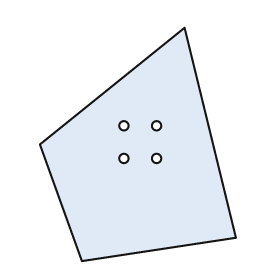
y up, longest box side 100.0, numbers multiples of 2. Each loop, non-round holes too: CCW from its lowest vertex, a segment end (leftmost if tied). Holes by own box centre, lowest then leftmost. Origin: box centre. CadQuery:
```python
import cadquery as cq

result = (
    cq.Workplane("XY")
    .moveTo(-24.0, -50.0)
    .lineTo(42.0, -40.0)
    .lineTo(20.0, 50.0)
    .lineTo(-42.0, 0.0)
    .close()
    .moveTo(-6.0, -6.0)
    .circle(2.0)
    .moveTo(8.0, -6.0)
    .circle(2.0)
    .moveTo(-6.0, 8.0)
    .circle(2.0)
    .moveTo(8.0, 8.0)
    .circle(2.0)
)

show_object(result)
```